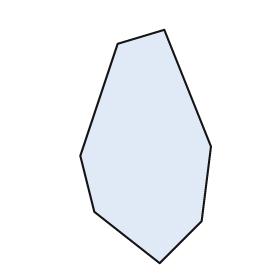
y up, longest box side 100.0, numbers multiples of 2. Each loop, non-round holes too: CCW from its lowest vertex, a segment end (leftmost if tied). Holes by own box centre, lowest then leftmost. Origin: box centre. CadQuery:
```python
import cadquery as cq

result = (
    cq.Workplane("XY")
    .moveTo(6.0, -50.0)
    .lineTo(24.0, -32.0)
    .lineTo(28.0, 0.0)
    .lineTo(8.0, 50.0)
    .lineTo(-12.0, 44.0)
    .lineTo(-28.0, -4.0)
    .lineTo(-22.0, -28.0)
    .close()
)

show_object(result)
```